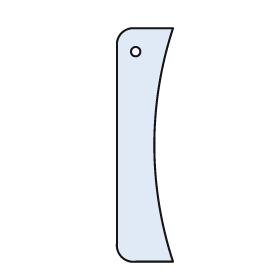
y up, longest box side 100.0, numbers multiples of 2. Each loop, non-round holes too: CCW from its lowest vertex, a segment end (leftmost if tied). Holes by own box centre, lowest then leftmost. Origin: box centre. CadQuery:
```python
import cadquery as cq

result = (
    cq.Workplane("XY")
    .moveTo(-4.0, -50.0)
    .lineTo(12.0, -50.0)
    .threePointArc((4.0, 0.0), (12.0, 50.0))
    .lineTo(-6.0, 50.0)
    .threePointArc((-10.0, 48.0), (-12.0, 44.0))
    .lineTo(-12.0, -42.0)
    .threePointArc((-10.0, -48.0), (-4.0, -50.0))
    .close()
    .moveTo(-4.0, 40.0)
    .circle(2.0)
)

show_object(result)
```